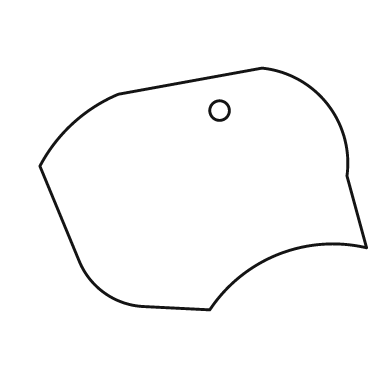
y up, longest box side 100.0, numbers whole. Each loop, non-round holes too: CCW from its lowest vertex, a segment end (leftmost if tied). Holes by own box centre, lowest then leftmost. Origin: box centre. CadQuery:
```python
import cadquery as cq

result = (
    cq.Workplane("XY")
    .moveTo(2.0, -37.0)
    .threePointArc((23.0, -20.0), (50.0, -18.0))
    .lineTo(44.0, 4.0)
    .threePointArc((38.0, 26.0), (18.0, 37.0))
    .lineTo(-26.0, 29.0)
    .threePointArc((-40.0, 20.0), (-50.0, 7.0))
    .lineTo(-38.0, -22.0)
    .threePointArc((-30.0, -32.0), (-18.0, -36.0))
    .close()
    .moveTo(5.0, 24.0)
    .circle(3.0)
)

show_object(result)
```